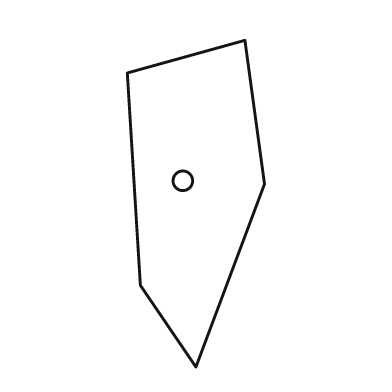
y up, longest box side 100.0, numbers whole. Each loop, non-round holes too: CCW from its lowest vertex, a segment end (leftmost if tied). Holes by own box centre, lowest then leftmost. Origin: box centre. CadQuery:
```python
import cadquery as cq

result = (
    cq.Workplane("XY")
    .moveTo(0.0, -50.0)
    .lineTo(21.0, 6.0)
    .lineTo(15.0, 50.0)
    .lineTo(-21.0, 40.0)
    .lineTo(-17.0, -25.0)
    .close()
    .moveTo(-4.0, 7.0)
    .circle(3.0)
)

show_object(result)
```